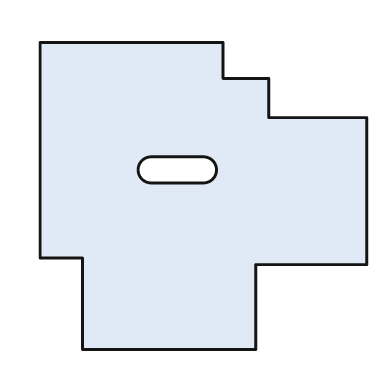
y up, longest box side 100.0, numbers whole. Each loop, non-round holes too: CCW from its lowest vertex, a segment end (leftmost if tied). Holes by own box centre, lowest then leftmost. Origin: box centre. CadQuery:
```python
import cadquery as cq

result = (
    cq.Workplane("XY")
    .moveTo(-37.0, -47.0)
    .lineTo(16.0, -47.0)
    .lineTo(16.0, -21.0)
    .lineTo(50.0, -21.0)
    .lineTo(50.0, 24.0)
    .lineTo(20.0, 24.0)
    .lineTo(20.0, 36.0)
    .lineTo(6.0, 36.0)
    .lineTo(6.0, 47.0)
    .lineTo(-50.0, 47.0)
    .lineTo(-50.0, -19.0)
    .lineTo(-37.0, -19.0)
    .close()
    .moveTo(-16.0, 4.0)
    .lineTo(0.0, 4.0)
    .threePointArc((4.0, 8.0), (0.0, 12.0))
    .lineTo(-16.0, 12.0)
    .threePointArc((-20.0, 8.0), (-16.0, 4.0))
    .close()
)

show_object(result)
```